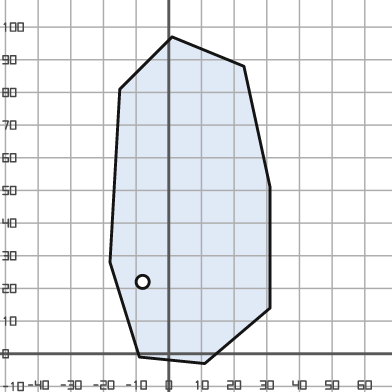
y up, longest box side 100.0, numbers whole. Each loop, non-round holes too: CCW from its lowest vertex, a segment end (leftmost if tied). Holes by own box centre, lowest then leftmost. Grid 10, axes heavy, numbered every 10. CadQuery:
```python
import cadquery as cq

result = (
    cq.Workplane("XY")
    .moveTo(11.0, -3.0)
    .lineTo(31.0, 14.0)
    .lineTo(31.0, 51.0)
    .lineTo(23.0, 88.0)
    .lineTo(1.0, 97.0)
    .lineTo(-15.0, 81.0)
    .lineTo(-18.0, 28.0)
    .lineTo(-9.0, -1.0)
    .close()
    .moveTo(-8.0, 22.0)
    .circle(2.0)
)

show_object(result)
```